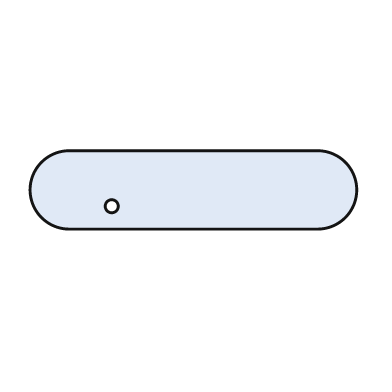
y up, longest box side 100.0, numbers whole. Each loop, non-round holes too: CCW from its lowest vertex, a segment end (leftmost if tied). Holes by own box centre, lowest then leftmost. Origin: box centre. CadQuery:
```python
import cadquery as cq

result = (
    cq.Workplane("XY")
    .moveTo(-38.0, -12.0)
    .lineTo(38.0, -12.0)
    .threePointArc((50.0, 0.0), (38.0, 12.0))
    .lineTo(-38.0, 12.0)
    .threePointArc((-50.0, 0.0), (-38.0, -12.0))
    .close()
    .moveTo(-25.0, -5.0)
    .circle(2.0)
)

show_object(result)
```